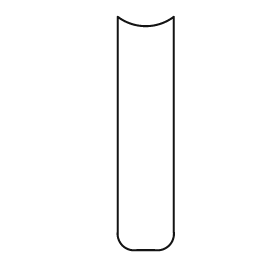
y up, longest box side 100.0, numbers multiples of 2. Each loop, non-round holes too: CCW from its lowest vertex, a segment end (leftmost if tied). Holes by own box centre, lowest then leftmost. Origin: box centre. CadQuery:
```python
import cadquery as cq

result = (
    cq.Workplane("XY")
    .moveTo(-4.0, -50.0)
    .lineTo(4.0, -50.0)
    .threePointArc((10.0, -48.0), (12.0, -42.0))
    .lineTo(12.0, 50.0)
    .threePointArc((0.0, 46.0), (-12.0, 50.0))
    .lineTo(-12.0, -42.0)
    .threePointArc((-10.0, -48.0), (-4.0, -50.0))
    .close()
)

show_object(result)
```